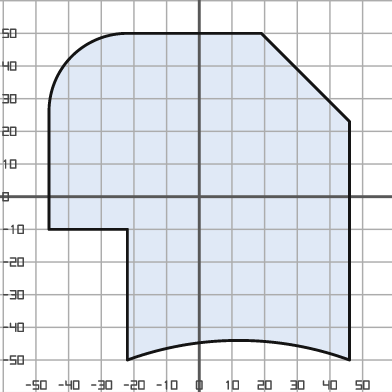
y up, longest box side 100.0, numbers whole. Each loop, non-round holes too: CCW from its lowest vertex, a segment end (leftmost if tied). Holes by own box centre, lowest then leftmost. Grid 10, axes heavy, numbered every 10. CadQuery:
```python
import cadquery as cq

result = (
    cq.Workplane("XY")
    .moveTo(-22.0, -50.0)
    .threePointArc((12.0, -44.0), (46.0, -50.0))
    .lineTo(46.0, 23.0)
    .lineTo(19.0, 50.0)
    .lineTo(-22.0, 50.0)
    .threePointArc((-39.0, 43.0), (-46.0, 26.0))
    .lineTo(-46.0, -10.0)
    .lineTo(-22.0, -10.0)
    .close()
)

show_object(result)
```